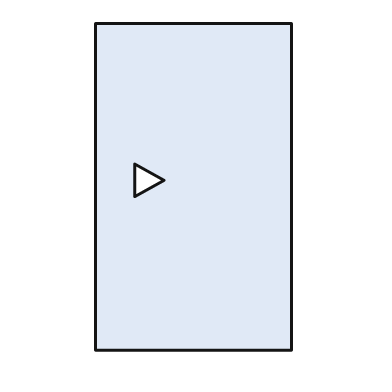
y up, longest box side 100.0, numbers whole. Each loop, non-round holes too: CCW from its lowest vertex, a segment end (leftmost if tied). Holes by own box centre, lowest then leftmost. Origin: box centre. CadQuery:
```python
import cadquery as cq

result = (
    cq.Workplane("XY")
    .moveTo(-30.0, -50.0)
    .lineTo(30.0, -50.0)
    .lineTo(30.0, 50.0)
    .lineTo(-30.0, 50.0)
    .close()
    .moveTo(-18.0, -3.0)
    .lineTo(-9.0, 2.0)
    .lineTo(-18.0, 7.0)
    .close()
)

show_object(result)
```